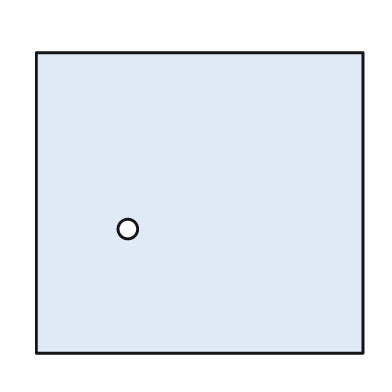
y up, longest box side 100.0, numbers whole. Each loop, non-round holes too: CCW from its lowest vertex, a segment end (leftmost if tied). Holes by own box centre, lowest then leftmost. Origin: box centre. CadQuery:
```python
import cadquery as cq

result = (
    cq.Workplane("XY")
    .moveTo(-50.0, -46.0)
    .lineTo(50.0, -46.0)
    .lineTo(50.0, 46.0)
    .lineTo(-50.0, 46.0)
    .close()
    .moveTo(-22.0, -8.0)
    .circle(3.0)
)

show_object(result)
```